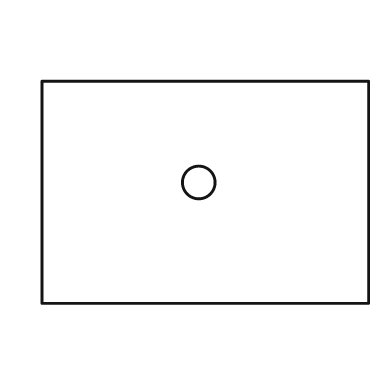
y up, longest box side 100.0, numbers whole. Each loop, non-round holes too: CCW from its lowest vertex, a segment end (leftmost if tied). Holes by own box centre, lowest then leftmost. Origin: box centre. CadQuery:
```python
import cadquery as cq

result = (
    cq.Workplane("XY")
    .moveTo(-50.0, -34.0)
    .lineTo(50.0, -34.0)
    .lineTo(50.0, 34.0)
    .lineTo(-50.0, 34.0)
    .close()
    .moveTo(-2.0, 3.0)
    .circle(5.0)
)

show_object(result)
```